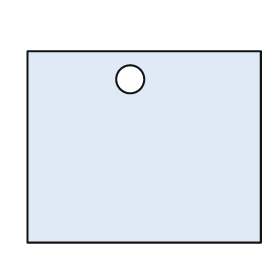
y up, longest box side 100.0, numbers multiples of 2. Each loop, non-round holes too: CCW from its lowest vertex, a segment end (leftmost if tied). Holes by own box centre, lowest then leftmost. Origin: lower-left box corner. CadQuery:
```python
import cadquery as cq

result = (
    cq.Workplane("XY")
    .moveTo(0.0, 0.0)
    .lineTo(100.0, 0.0)
    .lineTo(100.0, 82.0)
    .lineTo(0.0, 82.0)
    .close()
    .moveTo(44.0, 70.0)
    .circle(6.0)
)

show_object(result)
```